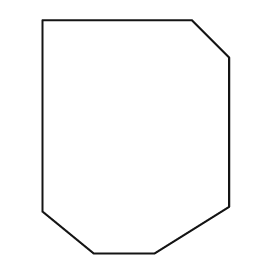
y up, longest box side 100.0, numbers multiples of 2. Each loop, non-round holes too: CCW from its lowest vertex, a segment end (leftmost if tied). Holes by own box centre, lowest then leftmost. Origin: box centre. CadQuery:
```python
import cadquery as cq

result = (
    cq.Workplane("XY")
    .moveTo(-18.0, -50.0)
    .lineTo(8.0, -50.0)
    .lineTo(40.0, -30.0)
    .lineTo(40.0, 34.0)
    .lineTo(24.0, 50.0)
    .lineTo(-40.0, 50.0)
    .lineTo(-40.0, -32.0)
    .close()
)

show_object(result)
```